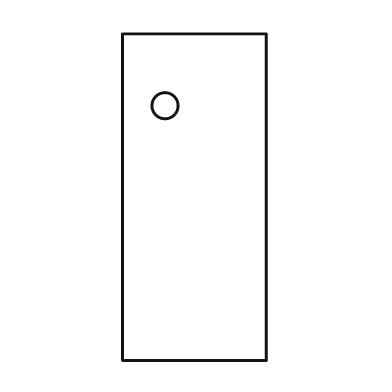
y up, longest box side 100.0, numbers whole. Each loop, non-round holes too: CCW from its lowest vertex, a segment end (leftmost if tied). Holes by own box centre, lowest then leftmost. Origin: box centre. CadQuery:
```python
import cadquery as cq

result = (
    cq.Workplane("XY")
    .moveTo(-22.0, -50.0)
    .lineTo(22.0, -50.0)
    .lineTo(22.0, 50.0)
    .lineTo(-22.0, 50.0)
    .close()
    .moveTo(-9.0, 28.0)
    .circle(4.0)
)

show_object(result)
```